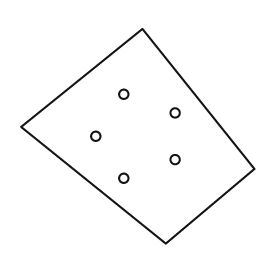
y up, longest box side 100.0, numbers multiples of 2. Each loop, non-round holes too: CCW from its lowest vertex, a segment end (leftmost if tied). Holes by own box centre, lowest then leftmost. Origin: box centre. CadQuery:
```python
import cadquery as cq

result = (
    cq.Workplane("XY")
    .moveTo(12.0, -46.0)
    .lineTo(50.0, -14.0)
    .lineTo(2.0, 46.0)
    .lineTo(-50.0, 4.0)
    .close()
    .moveTo(-6.0, -18.0)
    .circle(2.0)
    .moveTo(16.0, -10.0)
    .circle(2.0)
    .moveTo(-18.0, 0.0)
    .circle(2.0)
    .moveTo(16.0, 10.0)
    .circle(2.0)
    .moveTo(-6.0, 18.0)
    .circle(2.0)
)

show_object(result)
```